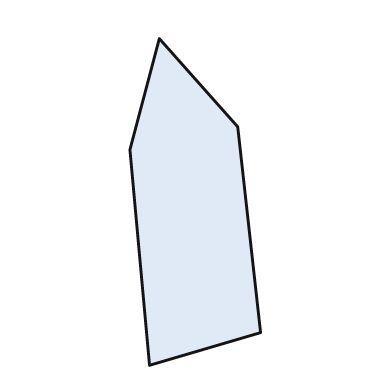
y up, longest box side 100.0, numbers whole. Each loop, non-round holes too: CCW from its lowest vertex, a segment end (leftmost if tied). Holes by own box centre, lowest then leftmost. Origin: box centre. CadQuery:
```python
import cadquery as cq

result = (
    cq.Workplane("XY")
    .moveTo(-14.0, -50.0)
    .lineTo(20.0, -40.0)
    .lineTo(13.0, 23.0)
    .lineTo(-11.0, 50.0)
    .lineTo(-20.0, 16.0)
    .close()
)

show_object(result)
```